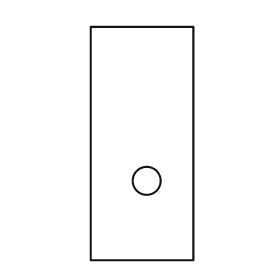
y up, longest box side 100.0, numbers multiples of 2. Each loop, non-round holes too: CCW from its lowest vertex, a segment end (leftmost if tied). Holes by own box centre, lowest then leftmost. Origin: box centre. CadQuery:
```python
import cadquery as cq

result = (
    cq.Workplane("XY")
    .moveTo(-22.0, -50.0)
    .lineTo(22.0, -50.0)
    .lineTo(22.0, 50.0)
    .lineTo(-22.0, 50.0)
    .close()
    .moveTo(2.0, -16.0)
    .circle(6.0)
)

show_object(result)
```